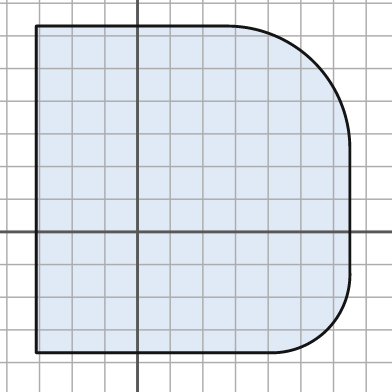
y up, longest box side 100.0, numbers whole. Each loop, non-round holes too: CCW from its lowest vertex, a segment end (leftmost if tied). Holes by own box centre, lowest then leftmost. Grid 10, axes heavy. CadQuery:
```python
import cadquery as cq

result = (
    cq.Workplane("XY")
    .moveTo(-31.0, -37.0)
    .lineTo(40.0, -37.0)
    .threePointArc((58.0, -30.0), (65.0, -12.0))
    .lineTo(65.0, 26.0)
    .threePointArc((54.0, 52.0), (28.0, 63.0))
    .lineTo(-31.0, 63.0)
    .close()
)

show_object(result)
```